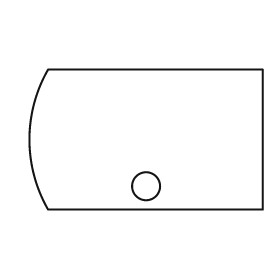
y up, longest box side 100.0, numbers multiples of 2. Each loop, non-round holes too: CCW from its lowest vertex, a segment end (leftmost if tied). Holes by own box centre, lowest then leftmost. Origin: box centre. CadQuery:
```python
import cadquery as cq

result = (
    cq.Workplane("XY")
    .moveTo(-42.0, -30.0)
    .lineTo(50.0, -30.0)
    .lineTo(50.0, 30.0)
    .lineTo(-42.0, 30.0)
    .threePointArc((-50.0, 0.0), (-42.0, -30.0))
    .close()
    .moveTo(0.0, -20.0)
    .circle(6.0)
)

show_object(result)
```